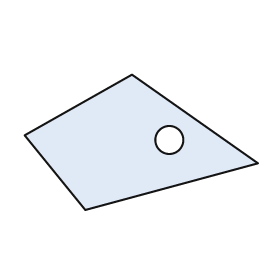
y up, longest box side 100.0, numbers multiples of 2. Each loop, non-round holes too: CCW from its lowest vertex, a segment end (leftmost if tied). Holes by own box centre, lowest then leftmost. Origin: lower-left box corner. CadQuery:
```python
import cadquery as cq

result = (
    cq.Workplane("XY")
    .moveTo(26.0, 0.0)
    .lineTo(100.0, 20.0)
    .lineTo(46.0, 58.0)
    .lineTo(0.0, 32.0)
    .close()
    .moveTo(62.0, 30.0)
    .circle(6.0)
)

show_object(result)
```